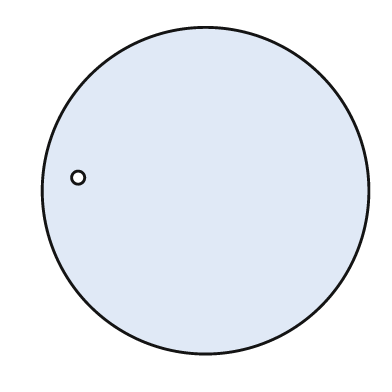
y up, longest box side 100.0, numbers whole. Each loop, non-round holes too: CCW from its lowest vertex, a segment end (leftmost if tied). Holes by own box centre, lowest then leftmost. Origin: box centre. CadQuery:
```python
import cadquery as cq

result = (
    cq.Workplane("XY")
    .moveTo(0.0, 0.0)
    .circle(50.0)
    .moveTo(-39.0, 4.0)
    .circle(2.0)
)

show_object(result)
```